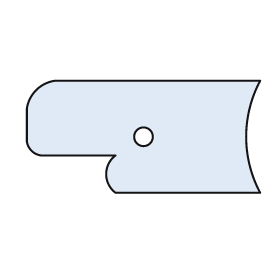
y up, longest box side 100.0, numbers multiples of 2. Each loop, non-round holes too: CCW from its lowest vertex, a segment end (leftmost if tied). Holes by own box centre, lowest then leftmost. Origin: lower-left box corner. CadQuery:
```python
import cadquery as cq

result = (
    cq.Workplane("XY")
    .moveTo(38.0, 0.0)
    .lineTo(100.0, 0.0)
    .threePointArc((94.0, 24.0), (100.0, 48.0))
    .lineTo(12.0, 48.0)
    .threePointArc((4.0, 44.0), (0.0, 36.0))
    .lineTo(0.0, 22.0)
    .threePointArc((2.0, 18.0), (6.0, 16.0))
    .lineTo(38.0, 16.0)
    .threePointArc((34.0, 8.0), (38.0, 0.0))
    .close()
    .moveTo(50.0, 24.0)
    .circle(4.0)
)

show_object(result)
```